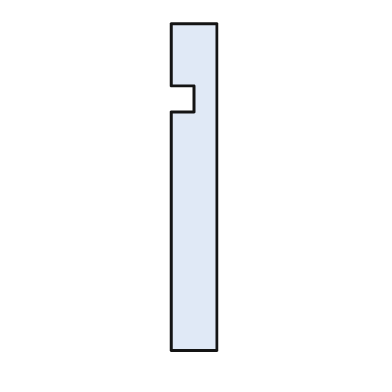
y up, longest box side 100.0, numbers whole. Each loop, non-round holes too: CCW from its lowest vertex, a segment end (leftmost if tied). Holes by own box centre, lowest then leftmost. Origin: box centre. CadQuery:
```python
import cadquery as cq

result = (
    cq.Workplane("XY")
    .moveTo(-7.0, -50.0)
    .lineTo(7.0, -50.0)
    .lineTo(7.0, 50.0)
    .lineTo(-7.0, 50.0)
    .lineTo(-7.0, 31.0)
    .lineTo(0.0, 31.0)
    .lineTo(0.0, 23.0)
    .lineTo(-7.0, 23.0)
    .close()
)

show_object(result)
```